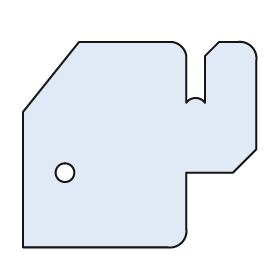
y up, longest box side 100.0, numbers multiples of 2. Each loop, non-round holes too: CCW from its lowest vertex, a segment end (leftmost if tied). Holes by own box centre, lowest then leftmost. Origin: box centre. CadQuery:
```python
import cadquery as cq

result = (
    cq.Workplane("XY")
    .moveTo(-50.0, -44.0)
    .lineTo(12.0, -44.0)
    .threePointArc((18.0, -42.0), (20.0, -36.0))
    .lineTo(20.0, -12.0)
    .lineTo(40.0, -12.0)
    .lineTo(50.0, -2.0)
    .lineTo(50.0, 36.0)
    .threePointArc((48.0, 42.0), (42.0, 44.0))
    .lineTo(34.0, 44.0)
    .lineTo(28.0, 38.0)
    .lineTo(28.0, 18.0)
    .threePointArc((24.0, 20.0), (20.0, 18.0))
    .lineTo(20.0, 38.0)
    .threePointArc((18.0, 42.0), (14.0, 44.0))
    .lineTo(-26.0, 44.0)
    .lineTo(-50.0, 14.0)
    .close()
    .moveTo(-32.0, -12.0)
    .circle(4.0)
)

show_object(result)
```